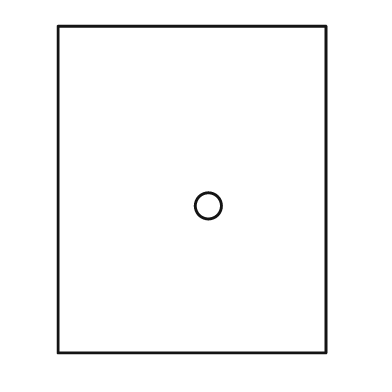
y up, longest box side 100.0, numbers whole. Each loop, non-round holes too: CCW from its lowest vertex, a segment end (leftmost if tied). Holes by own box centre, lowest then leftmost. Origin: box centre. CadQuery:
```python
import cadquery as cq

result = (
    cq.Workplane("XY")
    .moveTo(-41.0, -50.0)
    .lineTo(41.0, -50.0)
    .lineTo(41.0, 50.0)
    .lineTo(-41.0, 50.0)
    .close()
    .moveTo(5.0, -5.0)
    .circle(4.0)
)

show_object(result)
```